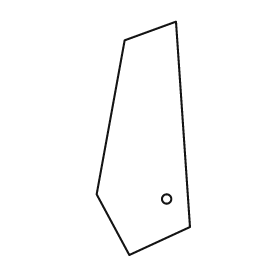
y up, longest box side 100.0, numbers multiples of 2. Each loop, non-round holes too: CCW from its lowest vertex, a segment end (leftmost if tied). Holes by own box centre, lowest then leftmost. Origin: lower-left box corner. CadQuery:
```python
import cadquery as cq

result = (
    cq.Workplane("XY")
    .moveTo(14.0, 0.0)
    .lineTo(40.0, 12.0)
    .lineTo(34.0, 100.0)
    .lineTo(12.0, 92.0)
    .lineTo(0.0, 26.0)
    .close()
    .moveTo(30.0, 24.0)
    .circle(2.0)
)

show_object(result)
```